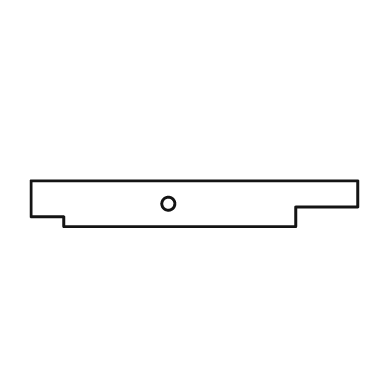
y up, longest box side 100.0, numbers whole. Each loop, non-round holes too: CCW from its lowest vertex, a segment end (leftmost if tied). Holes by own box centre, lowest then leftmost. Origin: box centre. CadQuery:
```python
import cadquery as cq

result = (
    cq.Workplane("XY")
    .moveTo(-40.0, -7.0)
    .lineTo(31.0, -7.0)
    .lineTo(31.0, -1.0)
    .lineTo(50.0, -1.0)
    .lineTo(50.0, 7.0)
    .lineTo(-50.0, 7.0)
    .lineTo(-50.0, -4.0)
    .lineTo(-40.0, -4.0)
    .close()
    .moveTo(-8.0, 0.0)
    .circle(2.0)
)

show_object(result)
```